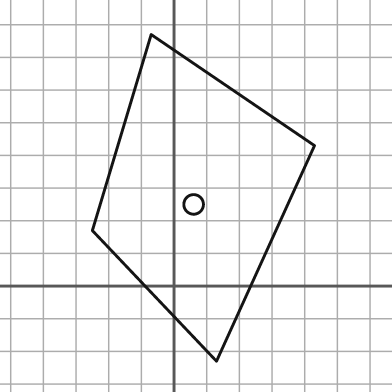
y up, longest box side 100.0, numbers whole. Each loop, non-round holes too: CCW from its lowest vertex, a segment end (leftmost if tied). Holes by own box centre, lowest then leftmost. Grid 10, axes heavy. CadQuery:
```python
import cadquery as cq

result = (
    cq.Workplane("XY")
    .moveTo(13.0, -23.0)
    .lineTo(43.0, 43.0)
    .lineTo(-7.0, 77.0)
    .lineTo(-25.0, 17.0)
    .close()
    .moveTo(6.0, 25.0)
    .circle(3.0)
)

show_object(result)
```